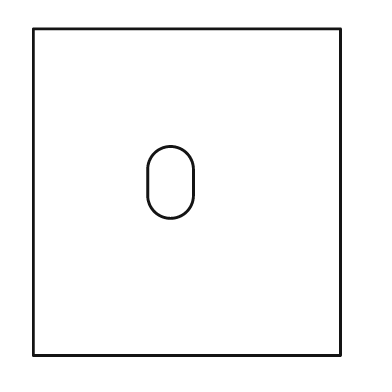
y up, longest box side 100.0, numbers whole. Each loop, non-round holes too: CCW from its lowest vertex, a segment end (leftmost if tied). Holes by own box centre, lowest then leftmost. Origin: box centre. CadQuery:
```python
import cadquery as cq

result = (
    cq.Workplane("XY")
    .moveTo(-47.0, -50.0)
    .lineTo(47.0, -50.0)
    .lineTo(47.0, 50.0)
    .lineTo(-47.0, 50.0)
    .close()
    .moveTo(-12.0, -1.0)
    .threePointArc((-5.0, -8.0), (2.0, -1.0))
    .lineTo(2.0, 7.0)
    .threePointArc((-5.0, 14.0), (-12.0, 7.0))
    .close()
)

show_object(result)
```